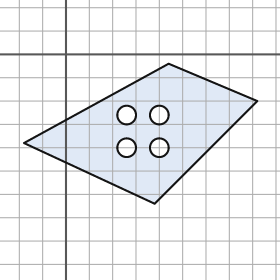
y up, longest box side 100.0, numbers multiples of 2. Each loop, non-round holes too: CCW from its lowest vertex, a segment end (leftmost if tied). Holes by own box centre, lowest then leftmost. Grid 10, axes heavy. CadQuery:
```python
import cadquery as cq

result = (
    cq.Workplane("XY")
    .moveTo(38.0, -64.0)
    .lineTo(82.0, -20.0)
    .lineTo(44.0, -4.0)
    .lineTo(-18.0, -38.0)
    .close()
    .moveTo(26.0, -40.0)
    .circle(4.0)
    .moveTo(40.0, -40.0)
    .circle(4.0)
    .moveTo(26.0, -26.0)
    .circle(4.0)
    .moveTo(40.0, -26.0)
    .circle(4.0)
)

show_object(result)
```